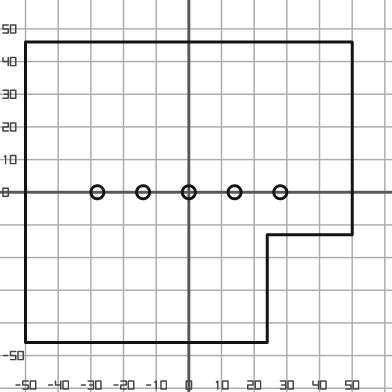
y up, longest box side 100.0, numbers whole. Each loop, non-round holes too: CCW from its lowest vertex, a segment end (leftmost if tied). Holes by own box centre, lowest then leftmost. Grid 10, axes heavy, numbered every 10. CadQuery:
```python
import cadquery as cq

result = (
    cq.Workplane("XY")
    .moveTo(-50.0, -46.0)
    .lineTo(24.0, -46.0)
    .lineTo(24.0, -13.0)
    .lineTo(50.0, -13.0)
    .lineTo(50.0, 46.0)
    .lineTo(-50.0, 46.0)
    .close()
    .moveTo(-28.0, 0.0)
    .circle(2.0)
    .moveTo(-14.0, 0.0)
    .circle(2.0)
    .moveTo(0.0, 0.0)
    .circle(2.0)
    .moveTo(14.0, 0.0)
    .circle(2.0)
    .moveTo(28.0, 0.0)
    .circle(2.0)
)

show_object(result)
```